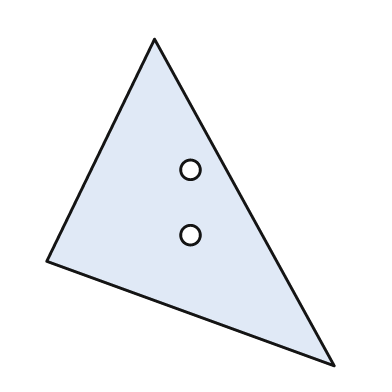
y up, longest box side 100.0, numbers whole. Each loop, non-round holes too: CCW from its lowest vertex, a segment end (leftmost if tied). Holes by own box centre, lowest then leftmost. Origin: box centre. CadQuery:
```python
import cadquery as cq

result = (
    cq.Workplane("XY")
    .moveTo(44.0, -50.0)
    .lineTo(-11.0, 50.0)
    .lineTo(-44.0, -18.0)
    .close()
    .moveTo(0.0, -10.0)
    .circle(3.0)
    .moveTo(0.0, 10.0)
    .circle(3.0)
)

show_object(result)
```